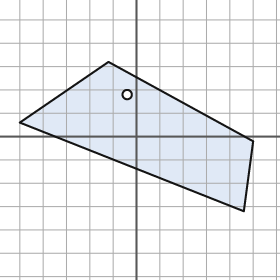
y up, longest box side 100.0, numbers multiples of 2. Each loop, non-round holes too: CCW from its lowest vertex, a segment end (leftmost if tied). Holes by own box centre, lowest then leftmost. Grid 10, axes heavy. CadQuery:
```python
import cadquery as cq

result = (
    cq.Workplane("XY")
    .moveTo(46.0, -32.0)
    .lineTo(50.0, -2.0)
    .lineTo(-12.0, 32.0)
    .lineTo(-50.0, 6.0)
    .close()
    .moveTo(-4.0, 18.0)
    .circle(2.0)
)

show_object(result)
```